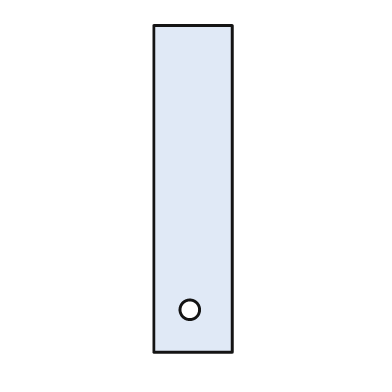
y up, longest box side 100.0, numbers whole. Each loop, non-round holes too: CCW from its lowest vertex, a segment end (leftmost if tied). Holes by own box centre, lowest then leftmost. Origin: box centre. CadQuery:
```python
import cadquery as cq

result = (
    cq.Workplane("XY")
    .moveTo(-12.0, -50.0)
    .lineTo(12.0, -50.0)
    .lineTo(12.0, 50.0)
    .lineTo(-12.0, 50.0)
    .close()
    .moveTo(-1.0, -37.0)
    .circle(3.0)
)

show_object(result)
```